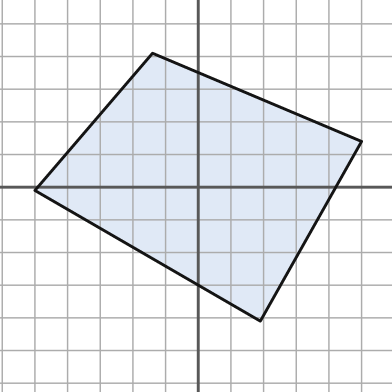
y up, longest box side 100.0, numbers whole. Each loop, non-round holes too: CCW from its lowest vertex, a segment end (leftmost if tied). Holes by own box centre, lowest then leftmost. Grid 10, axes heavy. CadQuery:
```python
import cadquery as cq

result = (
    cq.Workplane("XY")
    .moveTo(19.0, -41.0)
    .lineTo(50.0, 14.0)
    .lineTo(-14.0, 41.0)
    .lineTo(-50.0, -1.0)
    .close()
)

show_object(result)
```